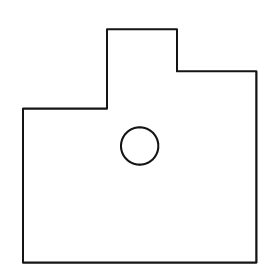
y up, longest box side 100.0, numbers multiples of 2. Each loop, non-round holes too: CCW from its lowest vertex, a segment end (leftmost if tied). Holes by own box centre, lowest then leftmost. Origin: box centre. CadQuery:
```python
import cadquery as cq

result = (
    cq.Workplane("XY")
    .moveTo(-50.0, -50.0)
    .lineTo(50.0, -50.0)
    .lineTo(50.0, 32.0)
    .lineTo(16.0, 32.0)
    .lineTo(16.0, 50.0)
    .lineTo(-14.0, 50.0)
    .lineTo(-14.0, 16.0)
    .lineTo(-50.0, 16.0)
    .close()
    .moveTo(0.0, 0.0)
    .circle(8.0)
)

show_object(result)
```